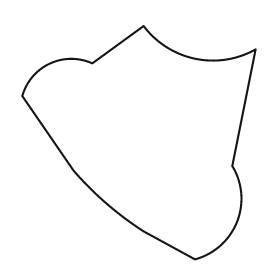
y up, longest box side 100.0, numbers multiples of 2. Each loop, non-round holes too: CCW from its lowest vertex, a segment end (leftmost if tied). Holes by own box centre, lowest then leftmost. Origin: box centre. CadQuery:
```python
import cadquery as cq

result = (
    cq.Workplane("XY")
    .moveTo(24.0, -50.0)
    .threePointArc((42.0, -34.0), (40.0, -10.0))
    .lineTo(50.0, 40.0)
    .threePointArc((24.0, 36.0), (2.0, 50.0))
    .lineTo(-20.0, 34.0)
    .threePointArc((-38.0, 34.0), (-50.0, 20.0))
    .lineTo(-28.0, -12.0)
    .threePointArc((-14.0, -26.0), (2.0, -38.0))
    .close()
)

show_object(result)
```